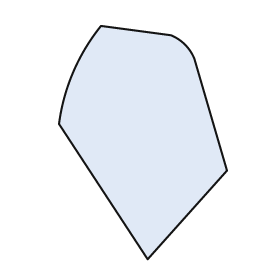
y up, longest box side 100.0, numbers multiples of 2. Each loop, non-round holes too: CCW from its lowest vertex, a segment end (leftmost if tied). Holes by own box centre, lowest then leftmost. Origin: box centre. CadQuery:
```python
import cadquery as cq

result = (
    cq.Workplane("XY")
    .moveTo(2.0, -50.0)
    .lineTo(36.0, -12.0)
    .lineTo(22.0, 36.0)
    .threePointArc((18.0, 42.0), (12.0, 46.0))
    .lineTo(-18.0, 50.0)
    .threePointArc((-30.0, 30.0), (-36.0, 8.0))
    .close()
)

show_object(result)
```